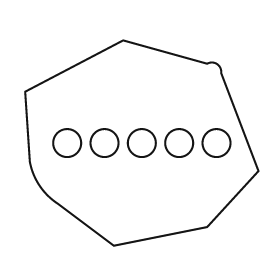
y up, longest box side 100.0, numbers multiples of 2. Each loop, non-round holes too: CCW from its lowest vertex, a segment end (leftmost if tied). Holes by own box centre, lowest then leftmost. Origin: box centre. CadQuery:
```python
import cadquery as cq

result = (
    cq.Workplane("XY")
    .moveTo(-12.0, -44.0)
    .lineTo(28.0, -36.0)
    .lineTo(50.0, -12.0)
    .lineTo(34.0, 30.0)
    .threePointArc((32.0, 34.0), (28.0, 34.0))
    .lineTo(-8.0, 44.0)
    .lineTo(-50.0, 22.0)
    .lineTo(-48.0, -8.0)
    .threePointArc((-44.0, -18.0), (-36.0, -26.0))
    .close()
    .moveTo(-32.0, 0.0)
    .circle(6.0)
    .moveTo(-16.0, 0.0)
    .circle(6.0)
    .moveTo(0.0, 0.0)
    .circle(6.0)
    .moveTo(16.0, 0.0)
    .circle(6.0)
    .moveTo(32.0, 0.0)
    .circle(6.0)
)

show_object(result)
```